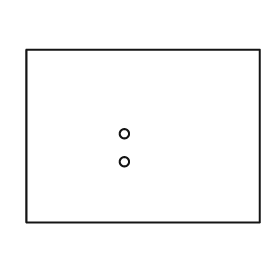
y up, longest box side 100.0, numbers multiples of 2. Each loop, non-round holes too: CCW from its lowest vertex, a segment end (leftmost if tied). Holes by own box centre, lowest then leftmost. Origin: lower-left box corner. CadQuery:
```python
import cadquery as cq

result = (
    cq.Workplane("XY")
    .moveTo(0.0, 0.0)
    .lineTo(100.0, 0.0)
    .lineTo(100.0, 74.0)
    .lineTo(0.0, 74.0)
    .close()
    .moveTo(42.0, 26.0)
    .circle(2.0)
    .moveTo(42.0, 38.0)
    .circle(2.0)
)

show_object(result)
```